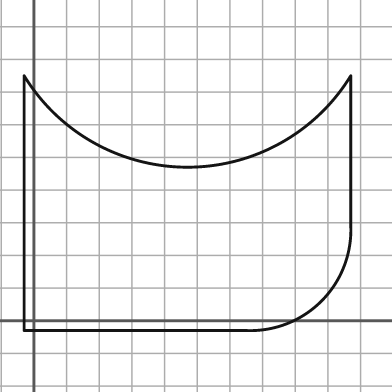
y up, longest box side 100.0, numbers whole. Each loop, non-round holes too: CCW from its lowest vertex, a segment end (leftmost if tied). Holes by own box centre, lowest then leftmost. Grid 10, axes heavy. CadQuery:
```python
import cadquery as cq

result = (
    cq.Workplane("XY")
    .moveTo(-3.0, -3.0)
    .lineTo(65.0, -3.0)
    .threePointArc((88.0, 6.0), (97.0, 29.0))
    .lineTo(97.0, 75.0)
    .threePointArc((47.0, 47.0), (-3.0, 75.0))
    .close()
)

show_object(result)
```